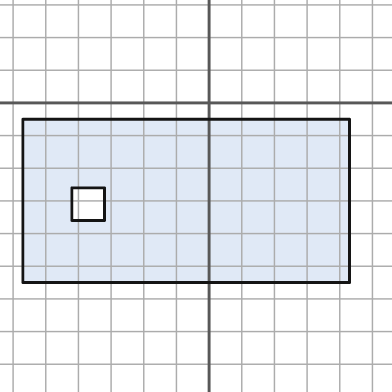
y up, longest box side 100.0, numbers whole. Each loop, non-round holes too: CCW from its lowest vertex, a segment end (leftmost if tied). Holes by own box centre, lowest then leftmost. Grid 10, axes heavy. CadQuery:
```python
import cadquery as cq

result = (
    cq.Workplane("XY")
    .moveTo(-57.0, -55.0)
    .lineTo(43.0, -55.0)
    .lineTo(43.0, -5.0)
    .lineTo(-57.0, -5.0)
    .close()
    .moveTo(-42.0, -36.0)
    .lineTo(-32.0, -36.0)
    .lineTo(-32.0, -26.0)
    .lineTo(-42.0, -26.0)
    .close()
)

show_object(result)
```